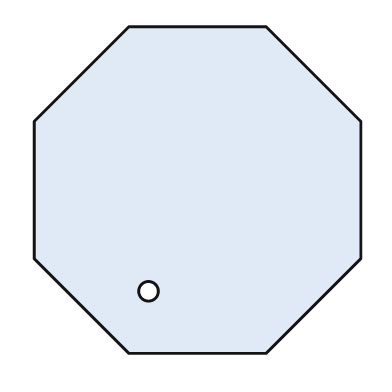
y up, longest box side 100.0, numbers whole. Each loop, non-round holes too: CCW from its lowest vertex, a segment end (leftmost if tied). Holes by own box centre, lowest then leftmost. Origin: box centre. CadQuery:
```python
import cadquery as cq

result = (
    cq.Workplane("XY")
    .moveTo(-21.0, -50.0)
    .lineTo(21.0, -50.0)
    .lineTo(50.0, -21.0)
    .lineTo(50.0, 21.0)
    .lineTo(21.0, 50.0)
    .lineTo(-21.0, 50.0)
    .lineTo(-50.0, 21.0)
    .lineTo(-50.0, -21.0)
    .close()
    .moveTo(-15.0, -31.0)
    .circle(3.0)
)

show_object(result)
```